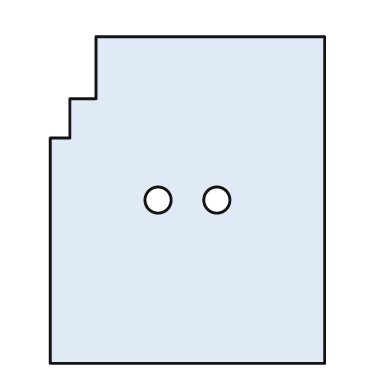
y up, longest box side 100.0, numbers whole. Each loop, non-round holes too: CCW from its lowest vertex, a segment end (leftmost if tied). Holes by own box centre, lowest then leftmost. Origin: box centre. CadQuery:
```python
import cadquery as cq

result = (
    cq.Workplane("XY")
    .moveTo(-42.0, -50.0)
    .lineTo(42.0, -50.0)
    .lineTo(42.0, 50.0)
    .lineTo(-28.0, 50.0)
    .lineTo(-28.0, 31.0)
    .lineTo(-36.0, 31.0)
    .lineTo(-36.0, 19.0)
    .lineTo(-42.0, 19.0)
    .close()
    .moveTo(-9.0, 0.0)
    .circle(4.0)
    .moveTo(9.0, 0.0)
    .circle(4.0)
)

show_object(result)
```